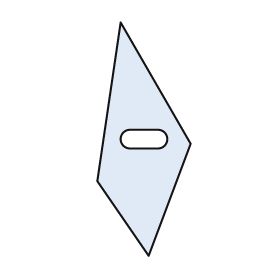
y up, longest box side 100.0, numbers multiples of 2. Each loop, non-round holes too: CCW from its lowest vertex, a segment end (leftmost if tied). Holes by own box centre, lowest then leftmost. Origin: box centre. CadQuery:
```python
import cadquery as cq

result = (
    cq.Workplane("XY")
    .moveTo(2.0, -50.0)
    .lineTo(20.0, -2.0)
    .lineTo(-10.0, 50.0)
    .lineTo(-20.0, -18.0)
    .close()
    .moveTo(-6.0, -4.0)
    .lineTo(6.0, -4.0)
    .threePointArc((10.0, 0.0), (6.0, 4.0))
    .lineTo(-6.0, 4.0)
    .threePointArc((-10.0, 0.0), (-6.0, -4.0))
    .close()
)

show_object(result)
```